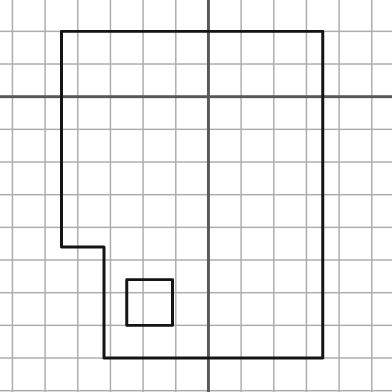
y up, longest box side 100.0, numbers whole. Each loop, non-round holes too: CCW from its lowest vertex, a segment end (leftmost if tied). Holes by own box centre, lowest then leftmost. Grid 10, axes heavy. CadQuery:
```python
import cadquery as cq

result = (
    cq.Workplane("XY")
    .moveTo(-32.0, -80.0)
    .lineTo(35.0, -80.0)
    .lineTo(35.0, 20.0)
    .lineTo(-45.0, 20.0)
    .lineTo(-45.0, -46.0)
    .lineTo(-32.0, -46.0)
    .close()
    .moveTo(-25.0, -70.0)
    .lineTo(-11.0, -70.0)
    .lineTo(-11.0, -56.0)
    .lineTo(-25.0, -56.0)
    .close()
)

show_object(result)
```